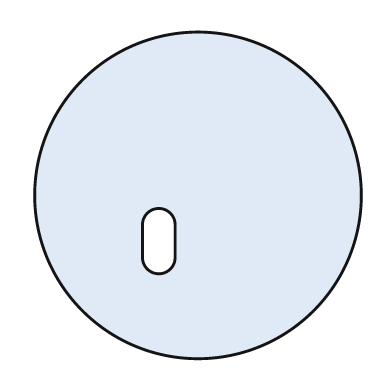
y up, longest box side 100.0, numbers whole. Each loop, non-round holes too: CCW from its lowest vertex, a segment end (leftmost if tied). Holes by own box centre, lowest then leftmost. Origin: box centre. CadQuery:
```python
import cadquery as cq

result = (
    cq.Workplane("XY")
    .moveTo(0.0, 0.0)
    .circle(50.0)
    .moveTo(-17.0, -19.0)
    .threePointArc((-12.0, -24.0), (-7.0, -19.0))
    .lineTo(-7.0, -9.0)
    .threePointArc((-12.0, -4.0), (-17.0, -9.0))
    .close()
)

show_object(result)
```